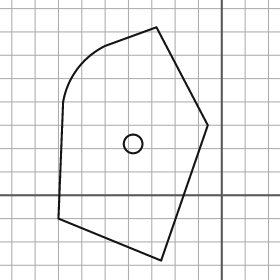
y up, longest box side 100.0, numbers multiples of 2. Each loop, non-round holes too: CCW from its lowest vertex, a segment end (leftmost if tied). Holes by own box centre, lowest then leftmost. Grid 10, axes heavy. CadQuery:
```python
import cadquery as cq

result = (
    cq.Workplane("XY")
    .moveTo(-26.0, -28.0)
    .lineTo(-6.0, 30.0)
    .lineTo(-28.0, 72.0)
    .lineTo(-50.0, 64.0)
    .threePointArc((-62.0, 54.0), (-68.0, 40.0))
    .lineTo(-70.0, -10.0)
    .close()
    .moveTo(-38.0, 22.0)
    .circle(4.0)
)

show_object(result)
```